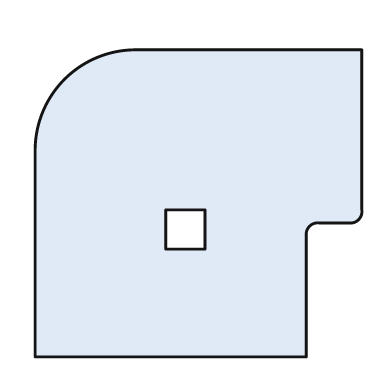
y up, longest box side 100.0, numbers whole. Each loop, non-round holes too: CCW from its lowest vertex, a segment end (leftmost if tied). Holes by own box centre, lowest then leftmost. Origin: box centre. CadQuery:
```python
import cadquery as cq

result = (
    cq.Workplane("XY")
    .moveTo(-50.0, -47.0)
    .lineTo(33.0, -47.0)
    .lineTo(33.0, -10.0)
    .threePointArc((34.0, -7.0), (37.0, -6.0))
    .lineTo(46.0, -6.0)
    .threePointArc((49.0, -5.0), (50.0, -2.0))
    .lineTo(50.0, 47.0)
    .lineTo(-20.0, 47.0)
    .threePointArc((-41.0, 38.0), (-50.0, 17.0))
    .close()
    .moveTo(-10.0, -14.0)
    .lineTo(2.0, -14.0)
    .lineTo(2.0, -2.0)
    .lineTo(-10.0, -2.0)
    .close()
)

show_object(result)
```